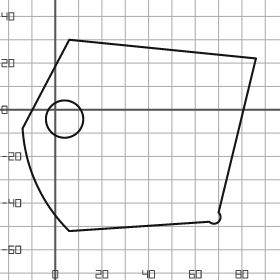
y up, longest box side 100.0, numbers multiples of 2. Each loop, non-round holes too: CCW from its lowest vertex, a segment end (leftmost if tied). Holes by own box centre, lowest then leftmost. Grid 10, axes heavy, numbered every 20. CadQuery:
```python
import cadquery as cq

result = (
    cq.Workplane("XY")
    .moveTo(6.0, -52.0)
    .lineTo(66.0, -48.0)
    .threePointArc((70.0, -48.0), (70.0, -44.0))
    .lineTo(86.0, 22.0)
    .lineTo(6.0, 30.0)
    .lineTo(-14.0, -8.0)
    .threePointArc((-8.0, -32.0), (6.0, -52.0))
    .close()
    .moveTo(4.0, -4.0)
    .circle(8.0)
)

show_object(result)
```